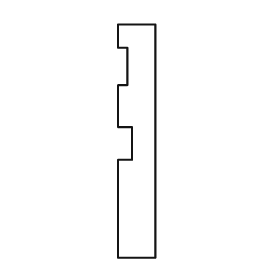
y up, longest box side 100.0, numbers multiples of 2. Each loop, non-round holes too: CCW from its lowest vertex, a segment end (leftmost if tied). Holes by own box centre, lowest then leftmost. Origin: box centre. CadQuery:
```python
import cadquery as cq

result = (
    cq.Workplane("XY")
    .moveTo(-8.0, -50.0)
    .lineTo(8.0, -50.0)
    .lineTo(8.0, 50.0)
    .lineTo(-8.0, 50.0)
    .lineTo(-8.0, 40.0)
    .lineTo(-4.0, 40.0)
    .lineTo(-4.0, 24.0)
    .lineTo(-8.0, 24.0)
    .lineTo(-8.0, 6.0)
    .lineTo(-2.0, 6.0)
    .lineTo(-2.0, -8.0)
    .lineTo(-8.0, -8.0)
    .close()
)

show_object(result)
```